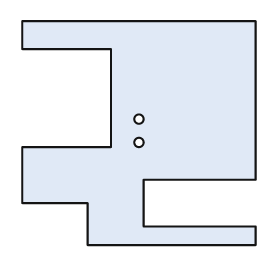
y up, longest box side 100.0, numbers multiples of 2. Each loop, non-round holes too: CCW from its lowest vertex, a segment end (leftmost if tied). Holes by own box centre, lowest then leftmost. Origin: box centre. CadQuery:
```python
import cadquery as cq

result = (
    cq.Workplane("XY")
    .moveTo(-22.0, -48.0)
    .lineTo(50.0, -48.0)
    .lineTo(50.0, -40.0)
    .lineTo(2.0, -40.0)
    .lineTo(2.0, -20.0)
    .lineTo(50.0, -20.0)
    .lineTo(50.0, 48.0)
    .lineTo(-50.0, 48.0)
    .lineTo(-50.0, 36.0)
    .lineTo(-12.0, 36.0)
    .lineTo(-12.0, -6.0)
    .lineTo(-50.0, -6.0)
    .lineTo(-50.0, -30.0)
    .lineTo(-22.0, -30.0)
    .close()
    .moveTo(0.0, -4.0)
    .circle(2.0)
    .moveTo(0.0, 6.0)
    .circle(2.0)
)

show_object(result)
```